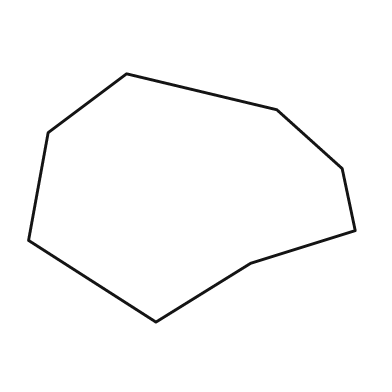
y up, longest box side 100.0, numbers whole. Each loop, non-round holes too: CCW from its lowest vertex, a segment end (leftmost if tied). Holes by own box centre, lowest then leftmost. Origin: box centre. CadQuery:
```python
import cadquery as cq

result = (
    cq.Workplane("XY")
    .moveTo(-11.0, -38.0)
    .lineTo(18.0, -20.0)
    .lineTo(50.0, -10.0)
    .lineTo(46.0, 9.0)
    .lineTo(26.0, 27.0)
    .lineTo(-20.0, 38.0)
    .lineTo(-44.0, 20.0)
    .lineTo(-50.0, -13.0)
    .close()
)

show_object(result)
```